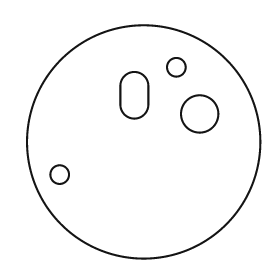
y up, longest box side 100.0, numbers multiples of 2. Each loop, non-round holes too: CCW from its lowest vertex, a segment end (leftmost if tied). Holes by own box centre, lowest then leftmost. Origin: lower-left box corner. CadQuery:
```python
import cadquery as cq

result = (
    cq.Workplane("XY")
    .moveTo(50.0, 50.0)
    .circle(50.0)
    .moveTo(14.0, 36.0)
    .circle(4.0)
    .moveTo(74.0, 62.0)
    .circle(8.0)
    .moveTo(40.0, 66.0)
    .threePointArc((46.0, 60.0), (52.0, 66.0))
    .lineTo(52.0, 74.0)
    .threePointArc((46.0, 80.0), (40.0, 74.0))
    .close()
    .moveTo(64.0, 82.0)
    .circle(4.0)
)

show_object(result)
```